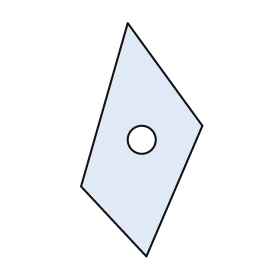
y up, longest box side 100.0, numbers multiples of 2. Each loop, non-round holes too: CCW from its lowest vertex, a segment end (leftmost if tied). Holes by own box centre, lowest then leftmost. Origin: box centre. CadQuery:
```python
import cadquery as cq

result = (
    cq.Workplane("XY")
    .moveTo(2.0, -50.0)
    .lineTo(26.0, 6.0)
    .lineTo(-6.0, 50.0)
    .lineTo(-26.0, -20.0)
    .close()
    .moveTo(0.0, 0.0)
    .circle(6.0)
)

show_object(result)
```